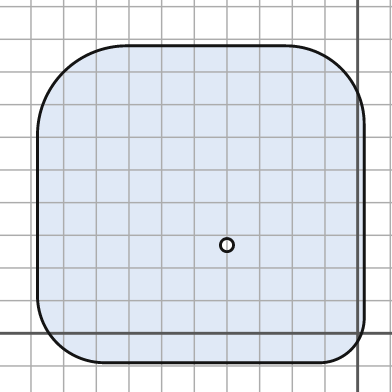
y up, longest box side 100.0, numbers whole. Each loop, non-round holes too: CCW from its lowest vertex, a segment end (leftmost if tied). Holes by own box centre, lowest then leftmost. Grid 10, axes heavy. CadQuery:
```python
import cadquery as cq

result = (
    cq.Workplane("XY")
    .moveTo(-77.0, -9.0)
    .lineTo(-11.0, -9.0)
    .threePointArc((-2.0, -5.0), (2.0, 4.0))
    .lineTo(2.0, 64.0)
    .threePointArc((-5.0, 81.0), (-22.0, 88.0))
    .lineTo(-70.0, 88.0)
    .threePointArc((-90.0, 80.0), (-98.0, 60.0))
    .lineTo(-98.0, 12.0)
    .threePointArc((-92.0, -3.0), (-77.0, -9.0))
    .close()
    .moveTo(-40.0, 27.0)
    .circle(2.0)
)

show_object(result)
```